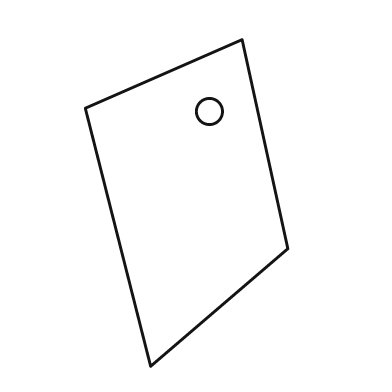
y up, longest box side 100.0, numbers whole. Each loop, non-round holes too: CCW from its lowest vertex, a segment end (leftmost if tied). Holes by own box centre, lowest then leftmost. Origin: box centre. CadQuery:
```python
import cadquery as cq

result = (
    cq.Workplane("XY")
    .moveTo(-11.0, -50.0)
    .lineTo(31.0, -14.0)
    .lineTo(17.0, 50.0)
    .lineTo(-31.0, 29.0)
    .close()
    .moveTo(7.0, 28.0)
    .circle(4.0)
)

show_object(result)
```